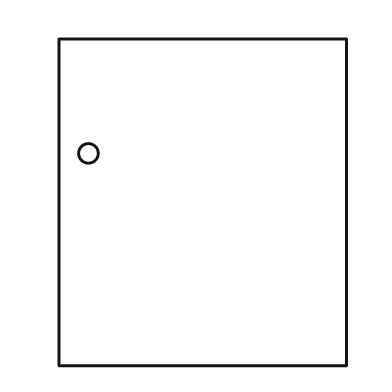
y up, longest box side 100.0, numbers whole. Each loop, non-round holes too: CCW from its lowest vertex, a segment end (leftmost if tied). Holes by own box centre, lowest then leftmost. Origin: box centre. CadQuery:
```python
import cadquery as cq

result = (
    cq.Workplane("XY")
    .moveTo(-44.0, -50.0)
    .lineTo(44.0, -50.0)
    .lineTo(44.0, 50.0)
    .lineTo(-44.0, 50.0)
    .close()
    .moveTo(-35.0, 15.0)
    .circle(3.0)
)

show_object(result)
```